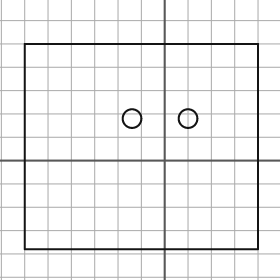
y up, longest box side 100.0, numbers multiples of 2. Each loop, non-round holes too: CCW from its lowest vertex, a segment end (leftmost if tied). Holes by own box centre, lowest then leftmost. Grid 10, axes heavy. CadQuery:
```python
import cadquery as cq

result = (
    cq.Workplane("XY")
    .moveTo(-60.0, -38.0)
    .lineTo(40.0, -38.0)
    .lineTo(40.0, 50.0)
    .lineTo(-60.0, 50.0)
    .close()
    .moveTo(-14.0, 18.0)
    .circle(4.0)
    .moveTo(10.0, 18.0)
    .circle(4.0)
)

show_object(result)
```